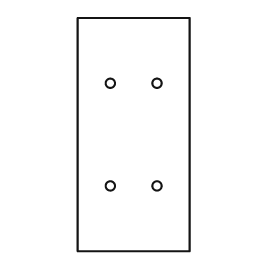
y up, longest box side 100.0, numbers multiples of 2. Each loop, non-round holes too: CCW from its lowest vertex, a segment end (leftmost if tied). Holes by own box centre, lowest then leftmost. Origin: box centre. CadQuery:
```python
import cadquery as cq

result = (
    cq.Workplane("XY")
    .moveTo(-24.0, -50.0)
    .lineTo(24.0, -50.0)
    .lineTo(24.0, 50.0)
    .lineTo(-24.0, 50.0)
    .close()
    .moveTo(-10.0, -22.0)
    .circle(2.0)
    .moveTo(10.0, -22.0)
    .circle(2.0)
    .moveTo(-10.0, 22.0)
    .circle(2.0)
    .moveTo(10.0, 22.0)
    .circle(2.0)
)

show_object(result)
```